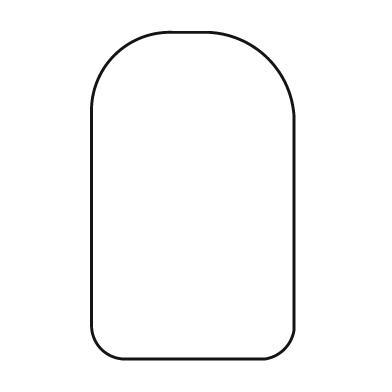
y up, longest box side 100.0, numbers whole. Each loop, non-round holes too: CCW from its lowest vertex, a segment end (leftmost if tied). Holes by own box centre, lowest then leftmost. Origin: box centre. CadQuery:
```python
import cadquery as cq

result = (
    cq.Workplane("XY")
    .moveTo(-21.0, -50.0)
    .lineTo(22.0, -50.0)
    .threePointArc((28.0, -47.0), (31.0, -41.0))
    .lineTo(31.0, 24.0)
    .threePointArc((23.0, 42.0), (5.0, 50.0))
    .lineTo(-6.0, 50.0)
    .threePointArc((-24.0, 43.0), (-31.0, 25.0))
    .lineTo(-31.0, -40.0)
    .threePointArc((-28.0, -47.0), (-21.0, -50.0))
    .close()
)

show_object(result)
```